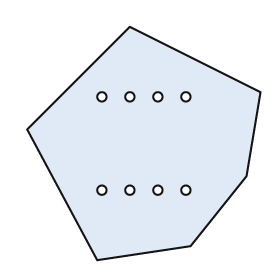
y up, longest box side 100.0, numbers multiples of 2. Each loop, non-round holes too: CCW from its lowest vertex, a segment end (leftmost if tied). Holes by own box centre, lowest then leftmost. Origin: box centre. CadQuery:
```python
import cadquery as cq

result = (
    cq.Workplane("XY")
    .moveTo(-20.0, -50.0)
    .lineTo(20.0, -44.0)
    .lineTo(44.0, -14.0)
    .lineTo(50.0, 22.0)
    .lineTo(-6.0, 50.0)
    .lineTo(-50.0, 6.0)
    .close()
    .moveTo(-18.0, -20.0)
    .circle(2.0)
    .moveTo(-6.0, -20.0)
    .circle(2.0)
    .moveTo(6.0, -20.0)
    .circle(2.0)
    .moveTo(18.0, -20.0)
    .circle(2.0)
    .moveTo(-18.0, 20.0)
    .circle(2.0)
    .moveTo(-6.0, 20.0)
    .circle(2.0)
    .moveTo(6.0, 20.0)
    .circle(2.0)
    .moveTo(18.0, 20.0)
    .circle(2.0)
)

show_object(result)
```